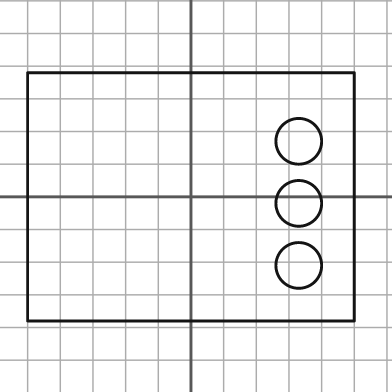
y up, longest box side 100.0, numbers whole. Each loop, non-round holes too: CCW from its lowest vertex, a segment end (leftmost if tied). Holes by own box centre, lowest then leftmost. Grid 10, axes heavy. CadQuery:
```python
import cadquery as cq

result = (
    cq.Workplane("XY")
    .moveTo(-50.0, -38.0)
    .lineTo(50.0, -38.0)
    .lineTo(50.0, 38.0)
    .lineTo(-50.0, 38.0)
    .close()
    .moveTo(33.0, -21.0)
    .circle(7.0)
    .moveTo(33.0, -2.0)
    .circle(7.0)
    .moveTo(33.0, 17.0)
    .circle(7.0)
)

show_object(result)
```